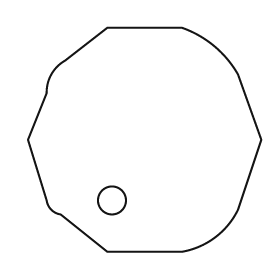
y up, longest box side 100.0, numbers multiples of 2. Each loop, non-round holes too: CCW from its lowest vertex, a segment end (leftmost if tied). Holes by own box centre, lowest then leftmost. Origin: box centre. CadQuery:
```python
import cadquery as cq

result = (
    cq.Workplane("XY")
    .moveTo(-16.0, -48.0)
    .lineTo(16.0, -48.0)
    .threePointArc((30.0, -42.0), (40.0, -30.0))
    .lineTo(50.0, 0.0)
    .lineTo(40.0, 28.0)
    .threePointArc((30.0, 40.0), (16.0, 48.0))
    .lineTo(-16.0, 48.0)
    .lineTo(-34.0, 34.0)
    .threePointArc((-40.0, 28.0), (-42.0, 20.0))
    .lineTo(-50.0, 0.0)
    .lineTo(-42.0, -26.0)
    .threePointArc((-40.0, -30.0), (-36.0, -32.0))
    .close()
    .moveTo(-14.0, -26.0)
    .circle(6.0)
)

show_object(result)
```